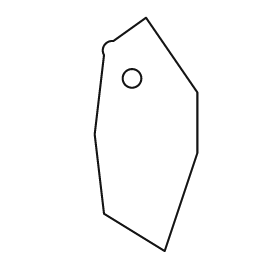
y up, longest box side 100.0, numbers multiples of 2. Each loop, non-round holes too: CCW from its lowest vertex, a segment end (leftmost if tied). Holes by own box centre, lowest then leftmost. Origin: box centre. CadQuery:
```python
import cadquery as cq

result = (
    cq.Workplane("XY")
    .moveTo(8.0, -50.0)
    .lineTo(22.0, -8.0)
    .lineTo(22.0, 18.0)
    .lineTo(0.0, 50.0)
    .lineTo(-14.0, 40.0)
    .threePointArc((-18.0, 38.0), (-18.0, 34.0))
    .lineTo(-22.0, 0.0)
    .lineTo(-18.0, -34.0)
    .close()
    .moveTo(-6.0, 24.0)
    .circle(4.0)
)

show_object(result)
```